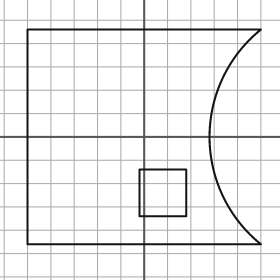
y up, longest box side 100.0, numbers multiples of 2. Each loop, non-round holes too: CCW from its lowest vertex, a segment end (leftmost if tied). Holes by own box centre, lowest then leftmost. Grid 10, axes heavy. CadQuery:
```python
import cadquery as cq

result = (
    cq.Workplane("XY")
    .moveTo(-50.0, -46.0)
    .lineTo(50.0, -46.0)
    .threePointArc((28.0, 0.0), (50.0, 46.0))
    .lineTo(-50.0, 46.0)
    .close()
    .moveTo(-2.0, -34.0)
    .lineTo(18.0, -34.0)
    .lineTo(18.0, -14.0)
    .lineTo(-2.0, -14.0)
    .close()
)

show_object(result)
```